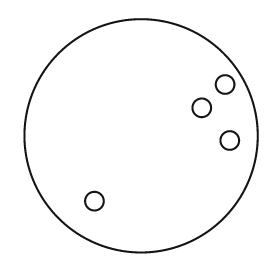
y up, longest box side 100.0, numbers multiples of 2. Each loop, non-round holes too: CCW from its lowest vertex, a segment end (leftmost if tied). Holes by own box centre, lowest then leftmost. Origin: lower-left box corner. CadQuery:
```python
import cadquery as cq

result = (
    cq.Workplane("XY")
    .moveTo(50.0, 50.0)
    .circle(50.0)
    .moveTo(30.0, 22.0)
    .circle(4.0)
    .moveTo(88.0, 48.0)
    .circle(4.0)
    .moveTo(76.0, 62.0)
    .circle(4.0)
    .moveTo(86.0, 72.0)
    .circle(4.0)
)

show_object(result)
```